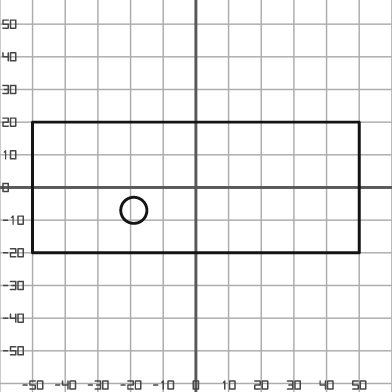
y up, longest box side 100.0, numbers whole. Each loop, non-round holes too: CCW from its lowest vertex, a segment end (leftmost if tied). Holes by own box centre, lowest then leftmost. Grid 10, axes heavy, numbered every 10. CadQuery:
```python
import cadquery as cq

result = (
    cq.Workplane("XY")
    .moveTo(-50.0, -20.0)
    .lineTo(50.0, -20.0)
    .lineTo(50.0, 20.0)
    .lineTo(-50.0, 20.0)
    .close()
    .moveTo(-19.0, -7.0)
    .circle(4.0)
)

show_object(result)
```